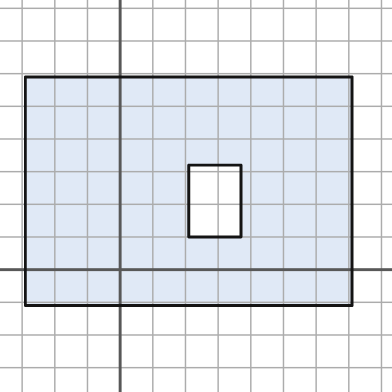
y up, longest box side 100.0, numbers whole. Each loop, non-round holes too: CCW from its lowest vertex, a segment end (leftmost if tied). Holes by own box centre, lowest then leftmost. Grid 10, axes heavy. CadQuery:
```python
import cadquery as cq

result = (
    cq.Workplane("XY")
    .moveTo(-29.0, -11.0)
    .lineTo(71.0, -11.0)
    .lineTo(71.0, 59.0)
    .lineTo(-29.0, 59.0)
    .close()
    .moveTo(21.0, 10.0)
    .lineTo(37.0, 10.0)
    .lineTo(37.0, 32.0)
    .lineTo(21.0, 32.0)
    .close()
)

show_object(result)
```